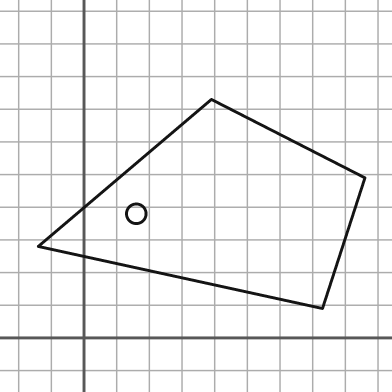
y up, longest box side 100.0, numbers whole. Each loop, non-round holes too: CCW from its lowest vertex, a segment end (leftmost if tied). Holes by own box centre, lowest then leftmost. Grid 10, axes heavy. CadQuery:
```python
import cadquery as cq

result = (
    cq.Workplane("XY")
    .moveTo(73.0, 9.0)
    .lineTo(86.0, 49.0)
    .lineTo(39.0, 73.0)
    .lineTo(-14.0, 28.0)
    .close()
    .moveTo(16.0, 38.0)
    .circle(3.0)
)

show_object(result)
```